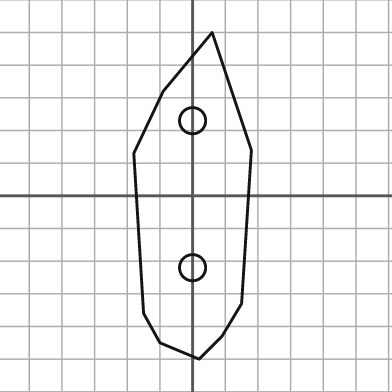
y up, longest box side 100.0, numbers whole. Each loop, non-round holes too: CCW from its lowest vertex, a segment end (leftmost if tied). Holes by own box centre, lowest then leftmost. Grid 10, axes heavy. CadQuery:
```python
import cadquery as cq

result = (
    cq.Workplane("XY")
    .moveTo(2.0, -50.0)
    .lineTo(9.0, -43.0)
    .lineTo(15.0, -33.0)
    .lineTo(18.0, 14.0)
    .lineTo(6.0, 50.0)
    .lineTo(-9.0, 32.0)
    .lineTo(-18.0, 13.0)
    .lineTo(-15.0, -36.0)
    .lineTo(-10.0, -45.0)
    .close()
    .moveTo(0.0, -22.0)
    .circle(4.0)
    .moveTo(0.0, 23.0)
    .circle(4.0)
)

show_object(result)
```